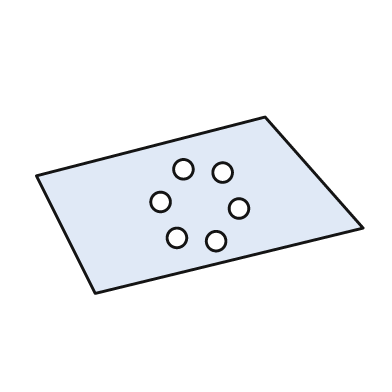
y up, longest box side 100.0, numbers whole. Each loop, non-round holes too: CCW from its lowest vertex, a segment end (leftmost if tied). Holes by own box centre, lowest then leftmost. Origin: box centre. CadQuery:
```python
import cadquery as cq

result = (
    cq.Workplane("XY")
    .moveTo(-32.0, -27.0)
    .lineTo(50.0, -7.0)
    .lineTo(20.0, 27.0)
    .lineTo(-50.0, 9.0)
    .close()
    .moveTo(5.0, -11.0)
    .circle(3.0)
    .moveTo(-7.0, -10.0)
    .circle(3.0)
    .moveTo(12.0, -1.0)
    .circle(3.0)
    .moveTo(-12.0, 1.0)
    .circle(3.0)
    .moveTo(7.0, 10.0)
    .circle(3.0)
    .moveTo(-5.0, 11.0)
    .circle(3.0)
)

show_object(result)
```